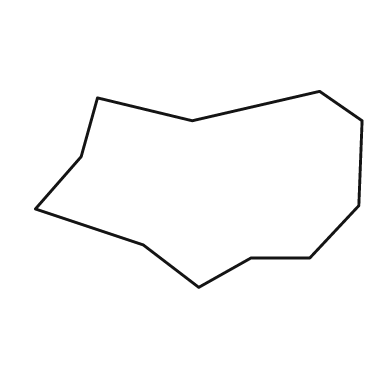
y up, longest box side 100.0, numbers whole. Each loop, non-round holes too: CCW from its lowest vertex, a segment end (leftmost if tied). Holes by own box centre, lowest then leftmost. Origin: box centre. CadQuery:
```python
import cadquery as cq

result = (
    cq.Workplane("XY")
    .moveTo(0.0, -30.0)
    .lineTo(16.0, -21.0)
    .lineTo(34.0, -21.0)
    .lineTo(49.0, -5.0)
    .lineTo(50.0, 21.0)
    .lineTo(37.0, 30.0)
    .lineTo(-2.0, 21.0)
    .lineTo(-31.0, 28.0)
    .lineTo(-36.0, 10.0)
    .lineTo(-50.0, -6.0)
    .lineTo(-17.0, -17.0)
    .close()
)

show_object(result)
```